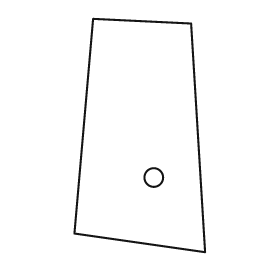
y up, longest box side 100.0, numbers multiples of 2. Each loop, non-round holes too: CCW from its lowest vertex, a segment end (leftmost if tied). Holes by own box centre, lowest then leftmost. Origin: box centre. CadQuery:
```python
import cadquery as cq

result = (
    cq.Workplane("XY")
    .moveTo(28.0, -50.0)
    .lineTo(22.0, 48.0)
    .lineTo(-20.0, 50.0)
    .lineTo(-28.0, -42.0)
    .close()
    .moveTo(6.0, -18.0)
    .circle(4.0)
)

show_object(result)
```